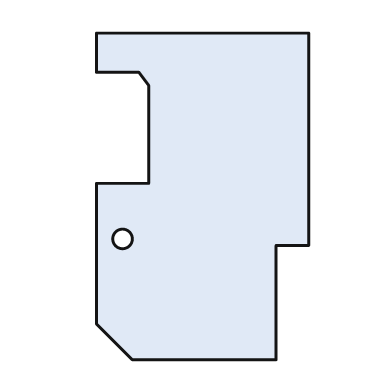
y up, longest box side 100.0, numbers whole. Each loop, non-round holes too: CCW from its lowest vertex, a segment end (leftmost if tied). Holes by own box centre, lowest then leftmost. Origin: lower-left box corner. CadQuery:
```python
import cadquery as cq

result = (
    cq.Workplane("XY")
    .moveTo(11.0, 0.0)
    .lineTo(55.0, 0.0)
    .lineTo(55.0, 35.0)
    .lineTo(65.0, 35.0)
    .lineTo(65.0, 100.0)
    .lineTo(0.0, 100.0)
    .lineTo(0.0, 88.0)
    .lineTo(13.0, 88.0)
    .lineTo(16.0, 84.0)
    .lineTo(16.0, 54.0)
    .lineTo(0.0, 54.0)
    .lineTo(0.0, 11.0)
    .close()
    .moveTo(8.0, 37.0)
    .circle(3.0)
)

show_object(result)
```